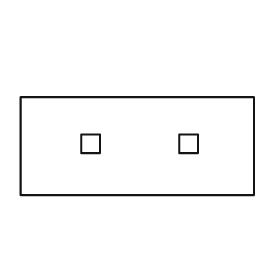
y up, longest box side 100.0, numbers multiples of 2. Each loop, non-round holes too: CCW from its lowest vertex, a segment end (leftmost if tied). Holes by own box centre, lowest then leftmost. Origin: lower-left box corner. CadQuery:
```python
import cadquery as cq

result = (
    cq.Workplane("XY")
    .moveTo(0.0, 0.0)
    .lineTo(100.0, 0.0)
    .lineTo(100.0, 42.0)
    .lineTo(0.0, 42.0)
    .close()
    .moveTo(26.0, 18.0)
    .lineTo(34.0, 18.0)
    .lineTo(34.0, 26.0)
    .lineTo(26.0, 26.0)
    .close()
    .moveTo(68.0, 18.0)
    .lineTo(76.0, 18.0)
    .lineTo(76.0, 26.0)
    .lineTo(68.0, 26.0)
    .close()
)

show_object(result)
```